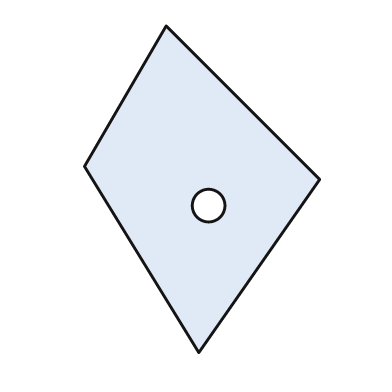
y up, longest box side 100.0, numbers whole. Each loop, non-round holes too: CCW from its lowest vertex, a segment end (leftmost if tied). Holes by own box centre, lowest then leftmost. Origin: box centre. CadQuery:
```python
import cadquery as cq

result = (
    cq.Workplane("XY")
    .moveTo(-1.0, -50.0)
    .lineTo(36.0, 3.0)
    .lineTo(-11.0, 50.0)
    .lineTo(-36.0, 7.0)
    .close()
    .moveTo(2.0, -5.0)
    .circle(5.0)
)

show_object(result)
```